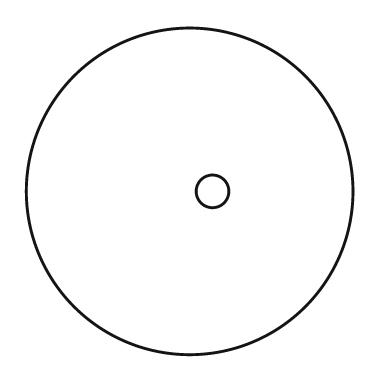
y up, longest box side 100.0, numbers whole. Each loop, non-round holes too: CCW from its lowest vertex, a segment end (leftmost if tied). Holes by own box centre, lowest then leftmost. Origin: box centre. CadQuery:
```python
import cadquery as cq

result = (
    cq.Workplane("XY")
    .moveTo(0.0, 0.0)
    .circle(50.0)
    .moveTo(7.0, 0.0)
    .circle(5.0)
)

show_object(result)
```